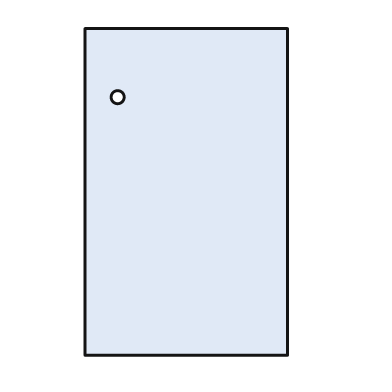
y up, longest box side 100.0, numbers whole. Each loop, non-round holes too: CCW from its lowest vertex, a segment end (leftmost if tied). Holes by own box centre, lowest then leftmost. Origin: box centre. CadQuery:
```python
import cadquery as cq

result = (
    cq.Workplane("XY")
    .moveTo(-31.0, -50.0)
    .lineTo(31.0, -50.0)
    .lineTo(31.0, 50.0)
    .lineTo(-31.0, 50.0)
    .close()
    .moveTo(-21.0, 29.0)
    .circle(2.0)
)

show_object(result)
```